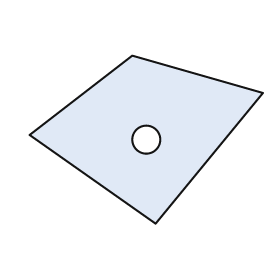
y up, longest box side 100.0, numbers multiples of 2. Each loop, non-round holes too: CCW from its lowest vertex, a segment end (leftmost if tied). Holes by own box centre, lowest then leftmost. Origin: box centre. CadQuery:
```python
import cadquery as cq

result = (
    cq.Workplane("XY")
    .moveTo(4.0, -36.0)
    .lineTo(50.0, 20.0)
    .lineTo(-6.0, 36.0)
    .lineTo(-50.0, 2.0)
    .close()
    .moveTo(0.0, 0.0)
    .circle(6.0)
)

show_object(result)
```